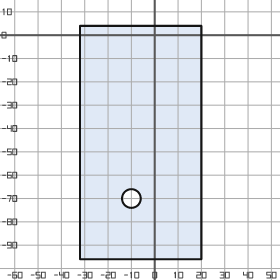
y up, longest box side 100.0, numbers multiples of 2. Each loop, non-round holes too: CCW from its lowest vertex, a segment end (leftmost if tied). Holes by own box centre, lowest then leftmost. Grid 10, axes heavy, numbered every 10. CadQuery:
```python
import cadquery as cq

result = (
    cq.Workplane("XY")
    .moveTo(-32.0, -96.0)
    .lineTo(20.0, -96.0)
    .lineTo(20.0, 4.0)
    .lineTo(-32.0, 4.0)
    .close()
    .moveTo(-10.0, -70.0)
    .circle(4.0)
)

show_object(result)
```